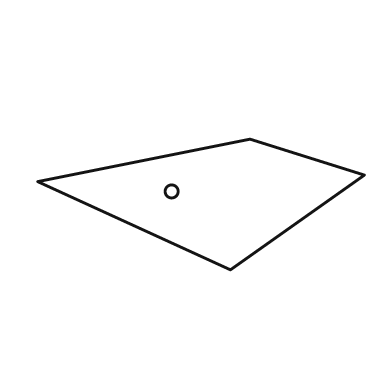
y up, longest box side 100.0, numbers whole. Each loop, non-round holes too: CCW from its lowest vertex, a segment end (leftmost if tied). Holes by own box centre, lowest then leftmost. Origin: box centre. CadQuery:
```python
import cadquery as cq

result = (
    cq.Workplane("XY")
    .moveTo(9.0, -20.0)
    .lineTo(50.0, 9.0)
    .lineTo(15.0, 20.0)
    .lineTo(-50.0, 7.0)
    .close()
    .moveTo(-9.0, 4.0)
    .circle(2.0)
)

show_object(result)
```